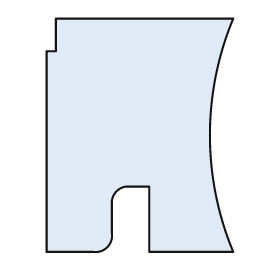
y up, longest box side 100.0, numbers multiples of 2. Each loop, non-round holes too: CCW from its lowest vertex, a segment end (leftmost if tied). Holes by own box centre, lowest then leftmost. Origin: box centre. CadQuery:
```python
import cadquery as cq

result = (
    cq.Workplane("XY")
    .moveTo(-40.0, -50.0)
    .lineTo(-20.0, -50.0)
    .threePointArc((-14.0, -48.0), (-12.0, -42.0))
    .lineTo(-12.0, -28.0)
    .threePointArc((-10.0, -24.0), (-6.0, -22.0))
    .lineTo(4.0, -22.0)
    .lineTo(4.0, -50.0)
    .lineTo(40.0, -50.0)
    .threePointArc((30.0, 0.0), (40.0, 50.0))
    .lineTo(-36.0, 50.0)
    .lineTo(-36.0, 36.0)
    .lineTo(-40.0, 36.0)
    .close()
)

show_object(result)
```